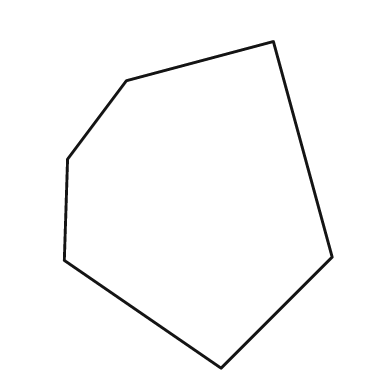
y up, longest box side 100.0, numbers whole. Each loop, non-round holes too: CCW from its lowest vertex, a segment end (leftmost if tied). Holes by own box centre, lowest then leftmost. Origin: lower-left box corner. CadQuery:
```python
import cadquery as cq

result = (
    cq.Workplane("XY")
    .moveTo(48.0, 0.0)
    .lineTo(82.0, 34.0)
    .lineTo(64.0, 100.0)
    .lineTo(19.0, 88.0)
    .lineTo(1.0, 64.0)
    .lineTo(0.0, 33.0)
    .close()
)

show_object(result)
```